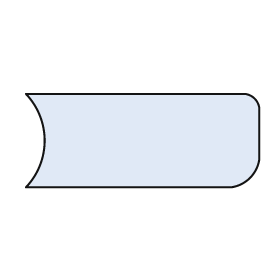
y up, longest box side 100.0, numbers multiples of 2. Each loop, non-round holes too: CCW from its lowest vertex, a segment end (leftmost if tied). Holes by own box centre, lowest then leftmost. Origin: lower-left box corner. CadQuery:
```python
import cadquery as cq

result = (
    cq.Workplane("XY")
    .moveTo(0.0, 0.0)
    .lineTo(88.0, 0.0)
    .threePointArc((96.0, 4.0), (100.0, 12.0))
    .lineTo(100.0, 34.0)
    .threePointArc((98.0, 38.0), (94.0, 40.0))
    .lineTo(0.0, 40.0)
    .threePointArc((8.0, 20.0), (0.0, 0.0))
    .close()
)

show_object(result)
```